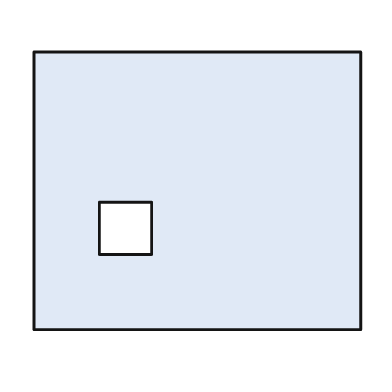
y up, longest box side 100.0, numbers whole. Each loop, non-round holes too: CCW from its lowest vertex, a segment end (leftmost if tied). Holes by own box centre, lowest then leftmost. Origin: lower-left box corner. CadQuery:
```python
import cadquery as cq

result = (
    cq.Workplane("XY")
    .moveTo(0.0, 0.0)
    .lineTo(100.0, 0.0)
    .lineTo(100.0, 85.0)
    .lineTo(0.0, 85.0)
    .close()
    .moveTo(20.0, 23.0)
    .lineTo(36.0, 23.0)
    .lineTo(36.0, 39.0)
    .lineTo(20.0, 39.0)
    .close()
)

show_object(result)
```